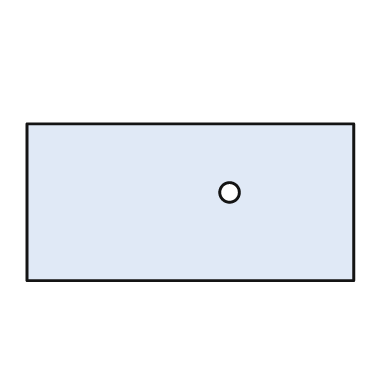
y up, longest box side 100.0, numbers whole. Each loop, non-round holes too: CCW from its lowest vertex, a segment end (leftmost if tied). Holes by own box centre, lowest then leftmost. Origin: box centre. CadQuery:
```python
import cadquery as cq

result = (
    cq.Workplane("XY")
    .moveTo(-50.0, -24.0)
    .lineTo(50.0, -24.0)
    .lineTo(50.0, 24.0)
    .lineTo(-50.0, 24.0)
    .close()
    .moveTo(12.0, 3.0)
    .circle(3.0)
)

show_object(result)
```